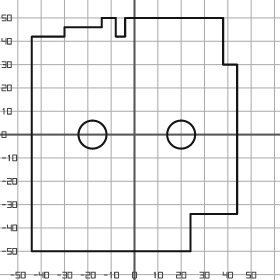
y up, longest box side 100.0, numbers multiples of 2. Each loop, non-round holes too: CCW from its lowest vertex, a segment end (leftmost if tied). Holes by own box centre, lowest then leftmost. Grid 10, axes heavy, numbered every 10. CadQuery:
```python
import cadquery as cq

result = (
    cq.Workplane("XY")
    .moveTo(-44.0, -50.0)
    .lineTo(24.0, -50.0)
    .lineTo(24.0, -34.0)
    .lineTo(44.0, -34.0)
    .lineTo(44.0, 30.0)
    .lineTo(38.0, 30.0)
    .lineTo(38.0, 50.0)
    .lineTo(-4.0, 50.0)
    .lineTo(-4.0, 42.0)
    .lineTo(-8.0, 42.0)
    .lineTo(-8.0, 50.0)
    .lineTo(-14.0, 50.0)
    .lineTo(-14.0, 46.0)
    .lineTo(-30.0, 46.0)
    .lineTo(-30.0, 42.0)
    .lineTo(-44.0, 42.0)
    .close()
    .moveTo(-18.0, 0.0)
    .circle(6.0)
    .moveTo(20.0, 0.0)
    .circle(6.0)
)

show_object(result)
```